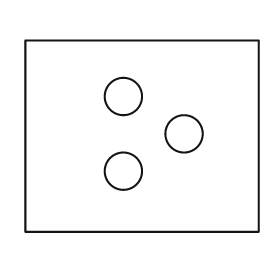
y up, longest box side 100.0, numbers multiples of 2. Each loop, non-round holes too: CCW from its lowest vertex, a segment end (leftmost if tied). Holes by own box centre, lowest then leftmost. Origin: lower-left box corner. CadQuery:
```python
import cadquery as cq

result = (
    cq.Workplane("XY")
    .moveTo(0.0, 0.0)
    .lineTo(100.0, 0.0)
    .lineTo(100.0, 82.0)
    .lineTo(0.0, 82.0)
    .close()
    .moveTo(42.0, 26.0)
    .circle(8.0)
    .moveTo(68.0, 42.0)
    .circle(8.0)
    .moveTo(42.0, 58.0)
    .circle(8.0)
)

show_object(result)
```